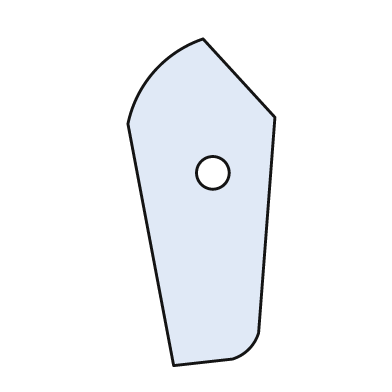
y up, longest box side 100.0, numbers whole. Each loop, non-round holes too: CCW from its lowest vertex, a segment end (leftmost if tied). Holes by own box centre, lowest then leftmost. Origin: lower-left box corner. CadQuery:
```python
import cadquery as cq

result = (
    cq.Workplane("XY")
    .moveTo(14.0, 0.0)
    .lineTo(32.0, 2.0)
    .threePointArc((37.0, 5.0), (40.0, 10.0))
    .lineTo(45.0, 76.0)
    .lineTo(23.0, 100.0)
    .threePointArc((8.0, 90.0), (0.0, 74.0))
    .close()
    .moveTo(26.0, 59.0)
    .circle(5.0)
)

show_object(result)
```